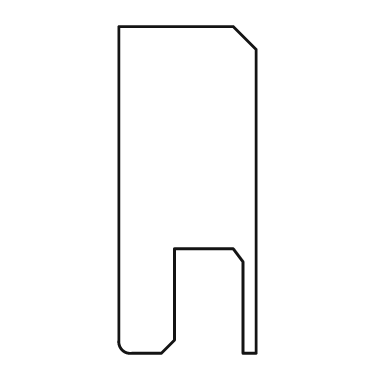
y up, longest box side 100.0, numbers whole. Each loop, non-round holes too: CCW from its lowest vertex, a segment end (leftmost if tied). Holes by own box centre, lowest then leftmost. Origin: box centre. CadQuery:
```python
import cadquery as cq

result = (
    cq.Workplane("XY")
    .moveTo(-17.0, -50.0)
    .lineTo(-8.0, -50.0)
    .lineTo(-4.0, -46.0)
    .lineTo(-4.0, -18.0)
    .lineTo(14.0, -18.0)
    .lineTo(17.0, -22.0)
    .lineTo(17.0, -50.0)
    .lineTo(21.0, -50.0)
    .lineTo(21.0, 43.0)
    .lineTo(14.0, 50.0)
    .lineTo(-21.0, 50.0)
    .lineTo(-21.0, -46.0)
    .threePointArc((-20.0, -49.0), (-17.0, -50.0))
    .close()
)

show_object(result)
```